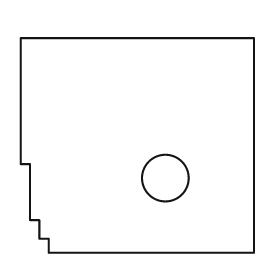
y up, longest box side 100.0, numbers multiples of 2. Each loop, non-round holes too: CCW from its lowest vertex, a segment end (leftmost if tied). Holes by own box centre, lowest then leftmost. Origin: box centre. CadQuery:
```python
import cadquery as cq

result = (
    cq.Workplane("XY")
    .moveTo(-38.0, -46.0)
    .lineTo(50.0, -46.0)
    .lineTo(50.0, 46.0)
    .lineTo(-50.0, 46.0)
    .lineTo(-50.0, -8.0)
    .lineTo(-46.0, -8.0)
    .lineTo(-46.0, -32.0)
    .lineTo(-42.0, -32.0)
    .lineTo(-42.0, -40.0)
    .lineTo(-38.0, -40.0)
    .close()
    .moveTo(12.0, -14.0)
    .circle(10.0)
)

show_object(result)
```